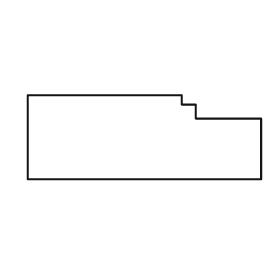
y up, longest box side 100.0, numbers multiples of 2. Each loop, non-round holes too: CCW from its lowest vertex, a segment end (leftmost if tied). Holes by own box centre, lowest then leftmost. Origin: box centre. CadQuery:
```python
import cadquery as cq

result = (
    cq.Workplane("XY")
    .moveTo(-50.0, -18.0)
    .lineTo(50.0, -18.0)
    .lineTo(50.0, 8.0)
    .lineTo(22.0, 8.0)
    .lineTo(22.0, 14.0)
    .lineTo(16.0, 14.0)
    .lineTo(16.0, 18.0)
    .lineTo(-50.0, 18.0)
    .close()
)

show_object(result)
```